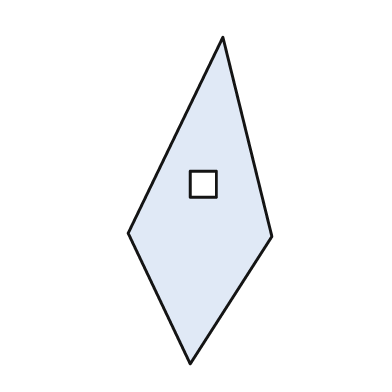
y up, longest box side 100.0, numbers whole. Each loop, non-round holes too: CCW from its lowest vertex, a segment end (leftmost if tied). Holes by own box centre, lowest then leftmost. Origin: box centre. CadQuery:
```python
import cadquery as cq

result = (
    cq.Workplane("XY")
    .moveTo(-3.0, -50.0)
    .lineTo(22.0, -11.0)
    .lineTo(7.0, 50.0)
    .lineTo(-22.0, -10.0)
    .close()
    .moveTo(-3.0, 1.0)
    .lineTo(5.0, 1.0)
    .lineTo(5.0, 9.0)
    .lineTo(-3.0, 9.0)
    .close()
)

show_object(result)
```